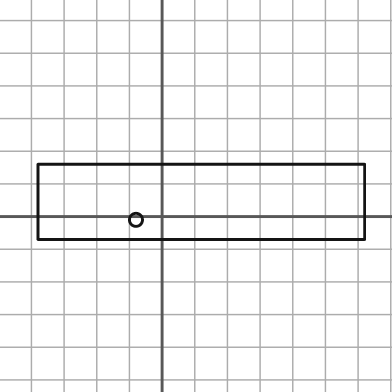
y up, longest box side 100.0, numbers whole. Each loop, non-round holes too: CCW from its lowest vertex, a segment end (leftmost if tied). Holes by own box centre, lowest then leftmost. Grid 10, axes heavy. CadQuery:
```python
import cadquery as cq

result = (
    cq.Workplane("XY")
    .moveTo(-38.0, -7.0)
    .lineTo(62.0, -7.0)
    .lineTo(62.0, 16.0)
    .lineTo(-38.0, 16.0)
    .close()
    .moveTo(-8.0, -1.0)
    .circle(2.0)
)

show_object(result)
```